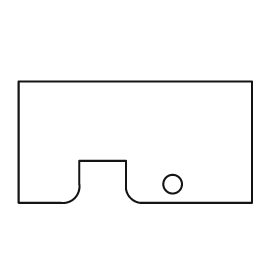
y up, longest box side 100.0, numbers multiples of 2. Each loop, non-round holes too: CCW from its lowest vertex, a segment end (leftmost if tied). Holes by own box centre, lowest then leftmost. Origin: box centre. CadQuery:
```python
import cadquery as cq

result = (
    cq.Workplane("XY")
    .moveTo(-50.0, -26.0)
    .lineTo(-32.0, -26.0)
    .threePointArc((-26.0, -24.0), (-24.0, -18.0))
    .lineTo(-24.0, -8.0)
    .lineTo(-4.0, -8.0)
    .lineTo(-4.0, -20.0)
    .threePointArc((-2.0, -24.0), (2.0, -26.0))
    .lineTo(50.0, -26.0)
    .lineTo(50.0, 26.0)
    .lineTo(-50.0, 26.0)
    .close()
    .moveTo(16.0, -18.0)
    .circle(4.0)
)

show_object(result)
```